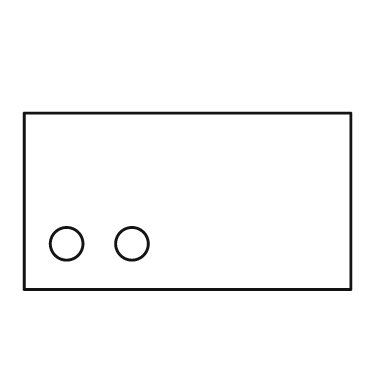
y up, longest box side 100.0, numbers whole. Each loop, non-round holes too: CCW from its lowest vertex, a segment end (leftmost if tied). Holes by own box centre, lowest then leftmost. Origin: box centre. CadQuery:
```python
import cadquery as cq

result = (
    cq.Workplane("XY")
    .moveTo(-50.0, -27.0)
    .lineTo(50.0, -27.0)
    .lineTo(50.0, 27.0)
    .lineTo(-50.0, 27.0)
    .close()
    .moveTo(-37.0, -13.0)
    .circle(5.0)
    .moveTo(-17.0, -13.0)
    .circle(5.0)
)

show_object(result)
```